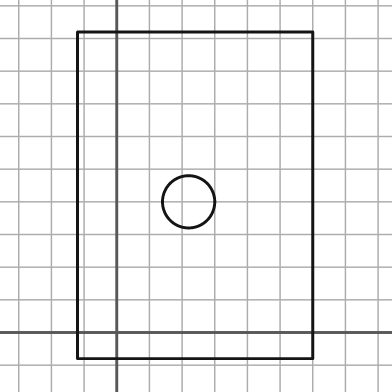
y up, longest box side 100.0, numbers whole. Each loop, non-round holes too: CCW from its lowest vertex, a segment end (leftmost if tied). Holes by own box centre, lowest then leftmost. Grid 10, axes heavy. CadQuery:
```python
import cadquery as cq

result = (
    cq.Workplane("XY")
    .moveTo(-12.0, -8.0)
    .lineTo(60.0, -8.0)
    .lineTo(60.0, 92.0)
    .lineTo(-12.0, 92.0)
    .close()
    .moveTo(22.0, 40.0)
    .circle(8.0)
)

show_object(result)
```